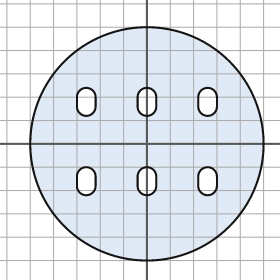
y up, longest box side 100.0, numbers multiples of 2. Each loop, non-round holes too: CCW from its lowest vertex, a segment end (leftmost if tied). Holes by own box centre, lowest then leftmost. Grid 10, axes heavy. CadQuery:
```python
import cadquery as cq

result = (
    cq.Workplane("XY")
    .moveTo(0.0, 0.0)
    .circle(50.0)
    .moveTo(-30.0, -18.0)
    .threePointArc((-26.0, -22.0), (-22.0, -18.0))
    .lineTo(-22.0, -14.0)
    .threePointArc((-26.0, -10.0), (-30.0, -14.0))
    .close()
    .moveTo(-4.0, -18.0)
    .threePointArc((0.0, -22.0), (4.0, -18.0))
    .lineTo(4.0, -14.0)
    .threePointArc((0.0, -10.0), (-4.0, -14.0))
    .close()
    .moveTo(22.0, -18.0)
    .threePointArc((26.0, -22.0), (30.0, -18.0))
    .lineTo(30.0, -14.0)
    .threePointArc((26.0, -10.0), (22.0, -14.0))
    .close()
    .moveTo(-30.0, 16.0)
    .threePointArc((-26.0, 12.0), (-22.0, 16.0))
    .lineTo(-22.0, 20.0)
    .threePointArc((-26.0, 24.0), (-30.0, 20.0))
    .close()
    .moveTo(-4.0, 16.0)
    .threePointArc((0.0, 12.0), (4.0, 16.0))
    .lineTo(4.0, 20.0)
    .threePointArc((0.0, 24.0), (-4.0, 20.0))
    .close()
    .moveTo(22.0, 16.0)
    .threePointArc((26.0, 12.0), (30.0, 16.0))
    .lineTo(30.0, 20.0)
    .threePointArc((26.0, 24.0), (22.0, 20.0))
    .close()
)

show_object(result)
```